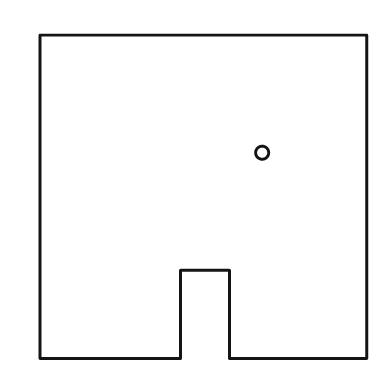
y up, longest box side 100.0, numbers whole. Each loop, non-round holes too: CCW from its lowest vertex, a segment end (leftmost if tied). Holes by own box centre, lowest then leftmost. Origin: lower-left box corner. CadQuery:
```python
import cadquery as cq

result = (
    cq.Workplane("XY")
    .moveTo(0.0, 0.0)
    .lineTo(43.0, 0.0)
    .lineTo(43.0, 27.0)
    .lineTo(58.0, 27.0)
    .lineTo(58.0, 0.0)
    .lineTo(100.0, 0.0)
    .lineTo(100.0, 99.0)
    .lineTo(0.0, 99.0)
    .close()
    .moveTo(68.0, 63.0)
    .circle(2.0)
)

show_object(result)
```